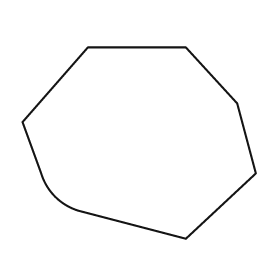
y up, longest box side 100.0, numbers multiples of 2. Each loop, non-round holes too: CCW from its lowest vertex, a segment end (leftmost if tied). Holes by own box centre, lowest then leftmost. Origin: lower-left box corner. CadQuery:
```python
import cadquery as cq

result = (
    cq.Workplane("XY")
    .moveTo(70.0, 0.0)
    .lineTo(100.0, 28.0)
    .lineTo(92.0, 58.0)
    .lineTo(70.0, 82.0)
    .lineTo(28.0, 82.0)
    .lineTo(0.0, 50.0)
    .lineTo(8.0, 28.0)
    .threePointArc((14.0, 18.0), (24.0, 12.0))
    .close()
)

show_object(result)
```